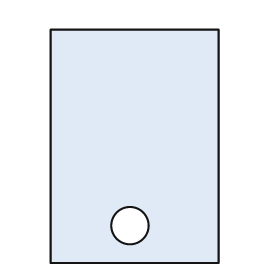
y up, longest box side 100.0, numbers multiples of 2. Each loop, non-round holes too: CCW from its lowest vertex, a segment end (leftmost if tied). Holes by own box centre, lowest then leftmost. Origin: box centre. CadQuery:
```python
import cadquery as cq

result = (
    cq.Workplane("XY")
    .moveTo(-36.0, -50.0)
    .lineTo(36.0, -50.0)
    .lineTo(36.0, 50.0)
    .lineTo(-36.0, 50.0)
    .close()
    .moveTo(-2.0, -34.0)
    .circle(8.0)
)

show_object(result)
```